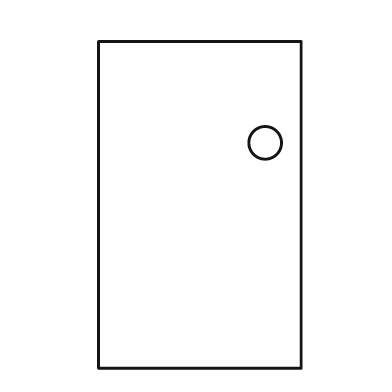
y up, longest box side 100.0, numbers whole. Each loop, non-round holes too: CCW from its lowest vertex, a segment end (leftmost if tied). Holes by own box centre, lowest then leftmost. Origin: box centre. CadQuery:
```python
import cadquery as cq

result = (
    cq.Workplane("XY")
    .moveTo(-31.0, -50.0)
    .lineTo(31.0, -50.0)
    .lineTo(31.0, 50.0)
    .lineTo(-31.0, 50.0)
    .close()
    .moveTo(20.0, 19.0)
    .circle(5.0)
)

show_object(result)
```